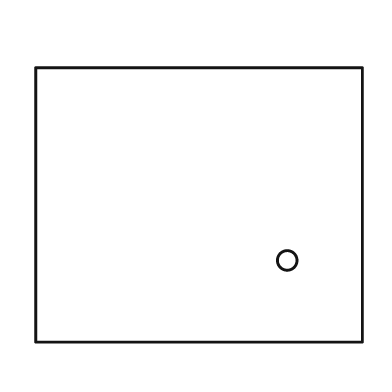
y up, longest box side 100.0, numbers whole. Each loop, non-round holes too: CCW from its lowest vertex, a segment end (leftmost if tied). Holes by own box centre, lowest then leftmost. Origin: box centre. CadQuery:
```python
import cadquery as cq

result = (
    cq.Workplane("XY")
    .moveTo(-50.0, -42.0)
    .lineTo(50.0, -42.0)
    .lineTo(50.0, 42.0)
    .lineTo(-50.0, 42.0)
    .close()
    .moveTo(27.0, -17.0)
    .circle(3.0)
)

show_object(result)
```